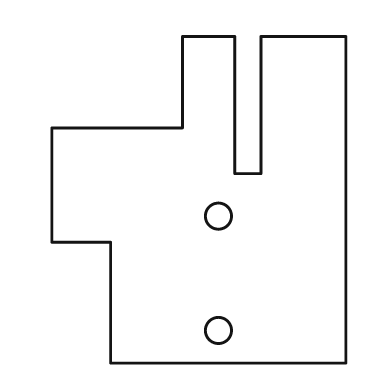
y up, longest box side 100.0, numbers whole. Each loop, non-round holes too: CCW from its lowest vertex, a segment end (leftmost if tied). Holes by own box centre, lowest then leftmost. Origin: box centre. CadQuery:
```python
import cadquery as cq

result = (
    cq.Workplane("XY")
    .moveTo(-27.0, -50.0)
    .lineTo(45.0, -50.0)
    .lineTo(45.0, 50.0)
    .lineTo(19.0, 50.0)
    .lineTo(19.0, 8.0)
    .lineTo(11.0, 8.0)
    .lineTo(11.0, 50.0)
    .lineTo(-5.0, 50.0)
    .lineTo(-5.0, 22.0)
    .lineTo(-45.0, 22.0)
    .lineTo(-45.0, -13.0)
    .lineTo(-27.0, -13.0)
    .close()
    .moveTo(6.0, -40.0)
    .circle(4.0)
    .moveTo(6.0, -5.0)
    .circle(4.0)
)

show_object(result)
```